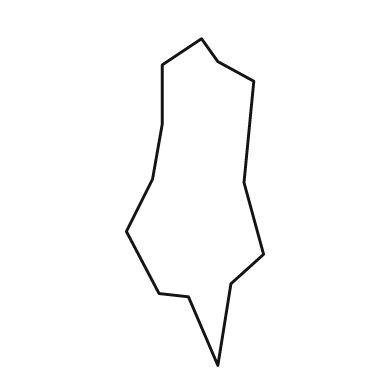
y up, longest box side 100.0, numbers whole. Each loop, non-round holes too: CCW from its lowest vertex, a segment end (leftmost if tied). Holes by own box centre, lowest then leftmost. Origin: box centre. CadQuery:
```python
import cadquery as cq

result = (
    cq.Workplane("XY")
    .moveTo(7.0, -50.0)
    .lineTo(11.0, -25.0)
    .lineTo(21.0, -16.0)
    .lineTo(15.0, 6.0)
    .lineTo(18.0, 37.0)
    .lineTo(7.0, 43.0)
    .lineTo(2.0, 50.0)
    .lineTo(-10.0, 42.0)
    .lineTo(-10.0, 24.0)
    .lineTo(-13.0, 7.0)
    .lineTo(-21.0, -9.0)
    .lineTo(-11.0, -28.0)
    .lineTo(-2.0, -29.0)
    .close()
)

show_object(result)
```